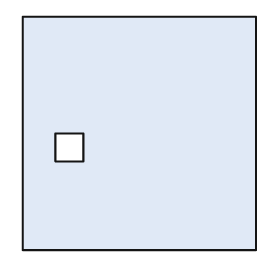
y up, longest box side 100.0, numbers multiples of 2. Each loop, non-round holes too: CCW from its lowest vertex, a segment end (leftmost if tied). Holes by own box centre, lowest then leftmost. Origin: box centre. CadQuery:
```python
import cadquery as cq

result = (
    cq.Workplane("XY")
    .moveTo(-50.0, -50.0)
    .lineTo(50.0, -50.0)
    .lineTo(50.0, 50.0)
    .lineTo(-50.0, 50.0)
    .close()
    .moveTo(-36.0, -12.0)
    .lineTo(-24.0, -12.0)
    .lineTo(-24.0, 0.0)
    .lineTo(-36.0, 0.0)
    .close()
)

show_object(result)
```